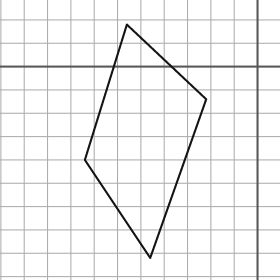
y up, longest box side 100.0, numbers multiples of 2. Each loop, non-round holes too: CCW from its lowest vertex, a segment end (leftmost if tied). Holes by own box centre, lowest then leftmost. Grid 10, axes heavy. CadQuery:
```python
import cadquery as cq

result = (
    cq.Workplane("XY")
    .moveTo(-46.0, -82.0)
    .lineTo(-22.0, -14.0)
    .lineTo(-56.0, 18.0)
    .lineTo(-74.0, -40.0)
    .close()
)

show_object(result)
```